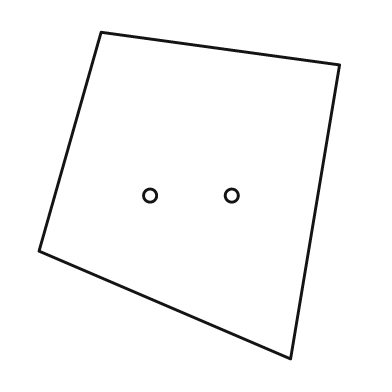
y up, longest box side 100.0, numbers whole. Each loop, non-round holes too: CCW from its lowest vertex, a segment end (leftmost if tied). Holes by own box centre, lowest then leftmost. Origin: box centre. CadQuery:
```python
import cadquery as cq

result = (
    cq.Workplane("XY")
    .moveTo(31.0, -50.0)
    .lineTo(46.0, 40.0)
    .lineTo(-27.0, 50.0)
    .lineTo(-46.0, -17.0)
    .close()
    .moveTo(-12.0, 0.0)
    .circle(2.0)
    .moveTo(13.0, 0.0)
    .circle(2.0)
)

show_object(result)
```